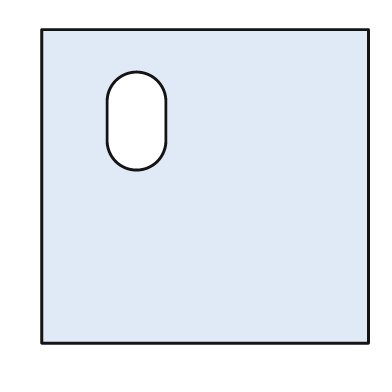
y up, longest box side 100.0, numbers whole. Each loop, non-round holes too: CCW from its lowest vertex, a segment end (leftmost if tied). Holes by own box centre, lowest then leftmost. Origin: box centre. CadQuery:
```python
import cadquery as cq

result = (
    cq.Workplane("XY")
    .moveTo(-50.0, -48.0)
    .lineTo(50.0, -48.0)
    .lineTo(50.0, 48.0)
    .lineTo(-50.0, 48.0)
    .close()
    .moveTo(-30.0, 14.0)
    .threePointArc((-21.0, 5.0), (-12.0, 14.0))
    .lineTo(-12.0, 26.0)
    .threePointArc((-21.0, 35.0), (-30.0, 26.0))
    .close()
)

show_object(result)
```